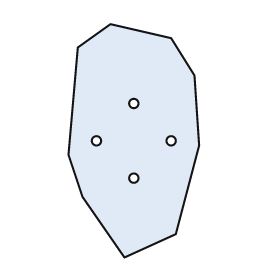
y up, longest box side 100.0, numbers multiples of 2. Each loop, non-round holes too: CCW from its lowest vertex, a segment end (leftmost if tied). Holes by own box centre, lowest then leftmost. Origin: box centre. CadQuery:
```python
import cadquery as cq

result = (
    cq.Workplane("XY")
    .moveTo(-4.0, -50.0)
    .lineTo(18.0, -40.0)
    .lineTo(28.0, -2.0)
    .lineTo(26.0, 28.0)
    .lineTo(16.0, 44.0)
    .lineTo(-10.0, 50.0)
    .lineTo(-24.0, 40.0)
    .lineTo(-28.0, -6.0)
    .lineTo(-22.0, -24.0)
    .close()
    .moveTo(0.0, -16.0)
    .circle(2.0)
    .moveTo(-16.0, 0.0)
    .circle(2.0)
    .moveTo(16.0, 0.0)
    .circle(2.0)
    .moveTo(0.0, 16.0)
    .circle(2.0)
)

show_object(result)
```